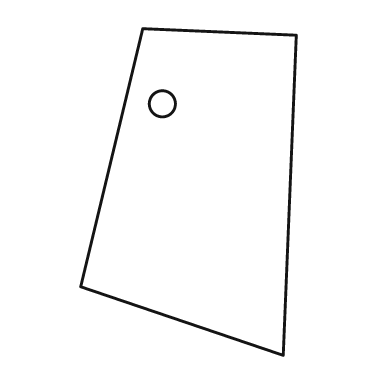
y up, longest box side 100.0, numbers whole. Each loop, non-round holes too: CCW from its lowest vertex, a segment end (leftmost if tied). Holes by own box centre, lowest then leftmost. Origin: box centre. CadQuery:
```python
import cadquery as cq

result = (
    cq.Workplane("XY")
    .moveTo(29.0, -50.0)
    .lineTo(33.0, 48.0)
    .lineTo(-14.0, 50.0)
    .lineTo(-33.0, -29.0)
    .close()
    .moveTo(-8.0, 27.0)
    .circle(4.0)
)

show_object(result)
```